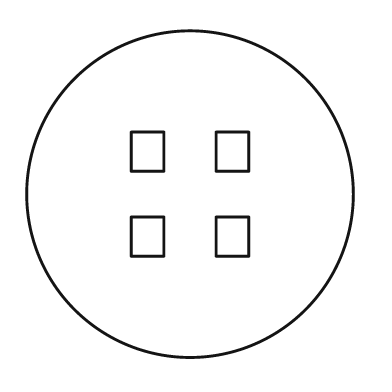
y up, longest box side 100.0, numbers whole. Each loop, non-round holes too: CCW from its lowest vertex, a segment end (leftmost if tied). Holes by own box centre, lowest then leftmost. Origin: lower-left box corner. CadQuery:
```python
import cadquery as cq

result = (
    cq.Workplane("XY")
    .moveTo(50.0, 50.0)
    .circle(50.0)
    .moveTo(32.0, 31.0)
    .lineTo(42.0, 31.0)
    .lineTo(42.0, 43.0)
    .lineTo(32.0, 43.0)
    .close()
    .moveTo(58.0, 31.0)
    .lineTo(68.0, 31.0)
    .lineTo(68.0, 43.0)
    .lineTo(58.0, 43.0)
    .close()
    .moveTo(32.0, 57.0)
    .lineTo(42.0, 57.0)
    .lineTo(42.0, 69.0)
    .lineTo(32.0, 69.0)
    .close()
    .moveTo(58.0, 57.0)
    .lineTo(68.0, 57.0)
    .lineTo(68.0, 69.0)
    .lineTo(58.0, 69.0)
    .close()
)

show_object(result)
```